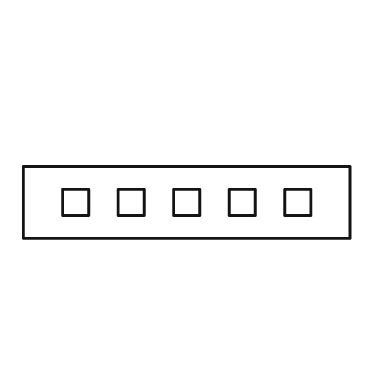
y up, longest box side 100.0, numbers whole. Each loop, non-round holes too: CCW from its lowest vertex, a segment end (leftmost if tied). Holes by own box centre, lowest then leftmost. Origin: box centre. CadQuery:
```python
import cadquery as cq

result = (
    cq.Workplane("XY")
    .moveTo(-50.0, -11.0)
    .lineTo(50.0, -11.0)
    .lineTo(50.0, 11.0)
    .lineTo(-50.0, 11.0)
    .close()
    .moveTo(-38.0, -4.0)
    .lineTo(-30.0, -4.0)
    .lineTo(-30.0, 4.0)
    .lineTo(-38.0, 4.0)
    .close()
    .moveTo(-21.0, -4.0)
    .lineTo(-13.0, -4.0)
    .lineTo(-13.0, 4.0)
    .lineTo(-21.0, 4.0)
    .close()
    .moveTo(-4.0, -4.0)
    .lineTo(4.0, -4.0)
    .lineTo(4.0, 4.0)
    .lineTo(-4.0, 4.0)
    .close()
    .moveTo(13.0, -4.0)
    .lineTo(21.0, -4.0)
    .lineTo(21.0, 4.0)
    .lineTo(13.0, 4.0)
    .close()
    .moveTo(30.0, -4.0)
    .lineTo(38.0, -4.0)
    .lineTo(38.0, 4.0)
    .lineTo(30.0, 4.0)
    .close()
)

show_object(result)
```